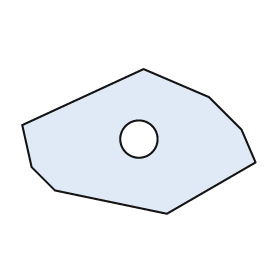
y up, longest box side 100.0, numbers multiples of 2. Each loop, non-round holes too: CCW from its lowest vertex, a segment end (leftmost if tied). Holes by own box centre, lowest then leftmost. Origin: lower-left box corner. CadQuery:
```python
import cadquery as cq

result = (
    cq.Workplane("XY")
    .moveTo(62.0, 0.0)
    .lineTo(100.0, 22.0)
    .lineTo(94.0, 36.0)
    .lineTo(80.0, 50.0)
    .lineTo(52.0, 62.0)
    .lineTo(0.0, 38.0)
    .lineTo(4.0, 20.0)
    .lineTo(14.0, 10.0)
    .close()
    .moveTo(50.0, 32.0)
    .circle(8.0)
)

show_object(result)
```